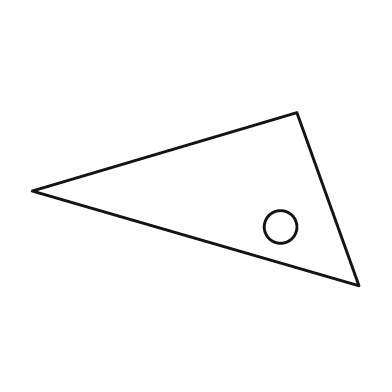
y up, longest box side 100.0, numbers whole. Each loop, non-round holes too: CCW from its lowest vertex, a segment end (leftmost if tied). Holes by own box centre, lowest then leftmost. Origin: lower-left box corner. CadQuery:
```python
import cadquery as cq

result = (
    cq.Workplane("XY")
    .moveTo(100.0, 0.0)
    .lineTo(81.0, 53.0)
    .lineTo(0.0, 29.0)
    .close()
    .moveTo(76.0, 18.0)
    .circle(5.0)
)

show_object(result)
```